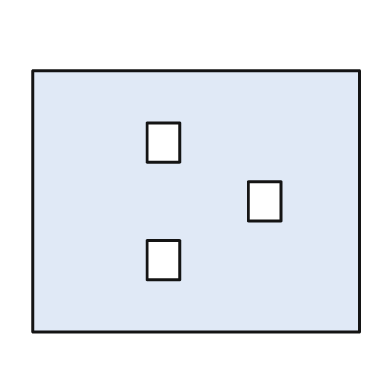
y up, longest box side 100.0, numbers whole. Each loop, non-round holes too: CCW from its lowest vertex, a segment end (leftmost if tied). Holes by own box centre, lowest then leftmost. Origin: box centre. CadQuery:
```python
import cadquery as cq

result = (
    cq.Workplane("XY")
    .moveTo(-50.0, -40.0)
    .lineTo(50.0, -40.0)
    .lineTo(50.0, 40.0)
    .lineTo(-50.0, 40.0)
    .close()
    .moveTo(-15.0, -24.0)
    .lineTo(-5.0, -24.0)
    .lineTo(-5.0, -12.0)
    .lineTo(-15.0, -12.0)
    .close()
    .moveTo(16.0, -6.0)
    .lineTo(26.0, -6.0)
    .lineTo(26.0, 6.0)
    .lineTo(16.0, 6.0)
    .close()
    .moveTo(-15.0, 12.0)
    .lineTo(-5.0, 12.0)
    .lineTo(-5.0, 24.0)
    .lineTo(-15.0, 24.0)
    .close()
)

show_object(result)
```